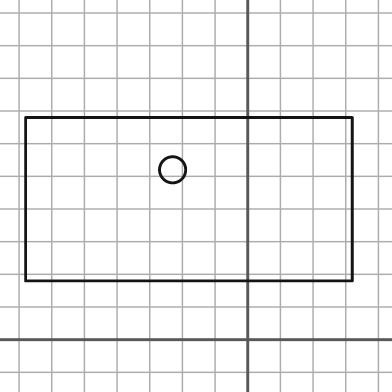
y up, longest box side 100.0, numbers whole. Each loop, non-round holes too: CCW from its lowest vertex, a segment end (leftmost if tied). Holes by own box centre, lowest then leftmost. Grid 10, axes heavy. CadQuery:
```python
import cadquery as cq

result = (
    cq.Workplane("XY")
    .moveTo(-68.0, 18.0)
    .lineTo(32.0, 18.0)
    .lineTo(32.0, 68.0)
    .lineTo(-68.0, 68.0)
    .close()
    .moveTo(-23.0, 52.0)
    .circle(4.0)
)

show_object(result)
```